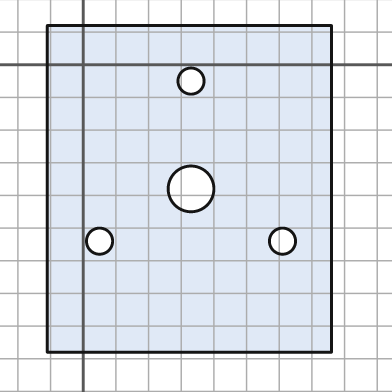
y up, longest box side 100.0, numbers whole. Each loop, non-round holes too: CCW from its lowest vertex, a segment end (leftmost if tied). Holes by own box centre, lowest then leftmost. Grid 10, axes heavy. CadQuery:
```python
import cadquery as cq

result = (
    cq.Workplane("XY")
    .moveTo(-11.0, -88.0)
    .lineTo(76.0, -88.0)
    .lineTo(76.0, 12.0)
    .lineTo(-11.0, 12.0)
    .close()
    .moveTo(5.0, -54.0)
    .circle(4.0)
    .moveTo(61.0, -54.0)
    .circle(4.0)
    .moveTo(33.0, -38.0)
    .circle(7.0)
    .moveTo(33.0, -5.0)
    .circle(4.0)
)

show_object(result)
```